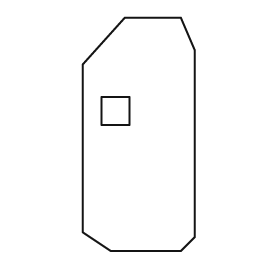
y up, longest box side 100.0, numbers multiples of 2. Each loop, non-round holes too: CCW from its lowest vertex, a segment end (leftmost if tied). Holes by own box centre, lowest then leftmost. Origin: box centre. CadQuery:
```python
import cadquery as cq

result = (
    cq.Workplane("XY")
    .moveTo(-12.0, -50.0)
    .lineTo(18.0, -50.0)
    .lineTo(24.0, -44.0)
    .lineTo(24.0, 36.0)
    .lineTo(18.0, 50.0)
    .lineTo(-6.0, 50.0)
    .lineTo(-24.0, 30.0)
    .lineTo(-24.0, -42.0)
    .close()
    .moveTo(-16.0, 4.0)
    .lineTo(-4.0, 4.0)
    .lineTo(-4.0, 16.0)
    .lineTo(-16.0, 16.0)
    .close()
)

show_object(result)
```